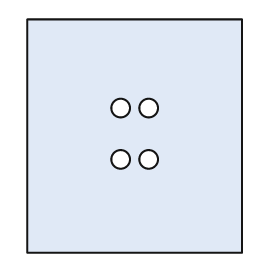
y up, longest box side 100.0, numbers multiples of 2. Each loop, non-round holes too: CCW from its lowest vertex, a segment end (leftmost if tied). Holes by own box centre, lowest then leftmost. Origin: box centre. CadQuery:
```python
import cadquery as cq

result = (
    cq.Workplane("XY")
    .moveTo(-46.0, -50.0)
    .lineTo(46.0, -50.0)
    .lineTo(46.0, 50.0)
    .lineTo(-46.0, 50.0)
    .close()
    .moveTo(-6.0, -10.0)
    .circle(4.0)
    .moveTo(6.0, -10.0)
    .circle(4.0)
    .moveTo(-6.0, 12.0)
    .circle(4.0)
    .moveTo(6.0, 12.0)
    .circle(4.0)
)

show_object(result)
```